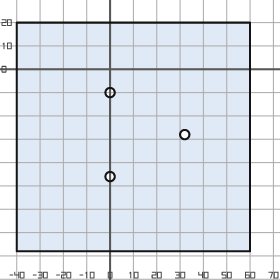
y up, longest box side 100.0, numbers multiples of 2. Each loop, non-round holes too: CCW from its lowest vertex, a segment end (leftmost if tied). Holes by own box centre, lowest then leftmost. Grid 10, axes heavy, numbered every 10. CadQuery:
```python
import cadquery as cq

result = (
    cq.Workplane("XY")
    .moveTo(-40.0, -78.0)
    .lineTo(60.0, -78.0)
    .lineTo(60.0, 20.0)
    .lineTo(-40.0, 20.0)
    .close()
    .moveTo(0.0, -46.0)
    .circle(2.0)
    .moveTo(32.0, -28.0)
    .circle(2.0)
    .moveTo(0.0, -10.0)
    .circle(2.0)
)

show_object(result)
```